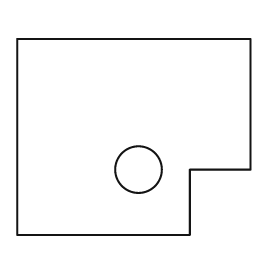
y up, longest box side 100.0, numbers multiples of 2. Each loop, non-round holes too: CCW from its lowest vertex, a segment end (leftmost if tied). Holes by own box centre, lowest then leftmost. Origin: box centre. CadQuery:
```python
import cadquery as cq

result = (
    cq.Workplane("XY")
    .moveTo(-50.0, -42.0)
    .lineTo(24.0, -42.0)
    .lineTo(24.0, -14.0)
    .lineTo(50.0, -14.0)
    .lineTo(50.0, 42.0)
    .lineTo(-50.0, 42.0)
    .close()
    .moveTo(2.0, -14.0)
    .circle(10.0)
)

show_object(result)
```